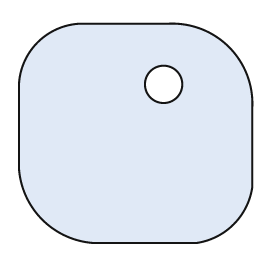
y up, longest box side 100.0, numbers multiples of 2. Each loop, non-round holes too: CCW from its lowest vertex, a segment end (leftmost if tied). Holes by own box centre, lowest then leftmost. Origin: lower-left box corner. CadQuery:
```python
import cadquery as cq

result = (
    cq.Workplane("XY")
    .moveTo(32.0, 0.0)
    .lineTo(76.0, 0.0)
    .threePointArc((92.0, 8.0), (100.0, 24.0))
    .lineTo(100.0, 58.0)
    .threePointArc((90.0, 84.0), (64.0, 94.0))
    .lineTo(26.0, 94.0)
    .threePointArc((8.0, 86.0), (0.0, 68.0))
    .lineTo(0.0, 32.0)
    .threePointArc((10.0, 10.0), (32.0, 0.0))
    .close()
    .moveTo(62.0, 68.0)
    .circle(8.0)
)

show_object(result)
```